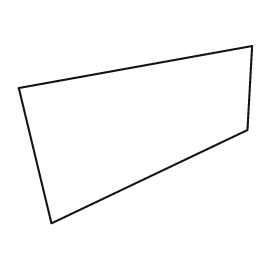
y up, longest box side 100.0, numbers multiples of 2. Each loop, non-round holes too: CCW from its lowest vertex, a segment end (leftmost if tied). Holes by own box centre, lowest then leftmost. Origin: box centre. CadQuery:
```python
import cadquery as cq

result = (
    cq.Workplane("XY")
    .moveTo(-36.0, -38.0)
    .lineTo(48.0, 2.0)
    .lineTo(50.0, 38.0)
    .lineTo(-50.0, 20.0)
    .close()
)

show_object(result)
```